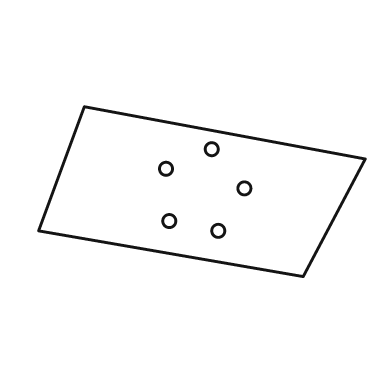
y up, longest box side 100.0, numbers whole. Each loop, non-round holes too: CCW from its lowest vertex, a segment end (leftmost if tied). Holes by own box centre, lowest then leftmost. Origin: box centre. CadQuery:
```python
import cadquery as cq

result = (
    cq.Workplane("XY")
    .moveTo(31.0, -26.0)
    .lineTo(50.0, 10.0)
    .lineTo(-36.0, 26.0)
    .lineTo(-50.0, -12.0)
    .close()
    .moveTo(5.0, -12.0)
    .circle(2.0)
    .moveTo(-10.0, -9.0)
    .circle(2.0)
    .moveTo(13.0, 1.0)
    .circle(2.0)
    .moveTo(-11.0, 7.0)
    .circle(2.0)
    .moveTo(3.0, 13.0)
    .circle(2.0)
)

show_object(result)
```